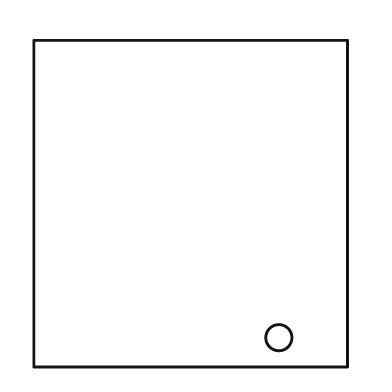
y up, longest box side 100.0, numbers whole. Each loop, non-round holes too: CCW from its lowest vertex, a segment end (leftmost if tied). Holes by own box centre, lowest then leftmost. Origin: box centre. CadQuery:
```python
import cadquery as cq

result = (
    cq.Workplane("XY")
    .moveTo(-48.0, -50.0)
    .lineTo(48.0, -50.0)
    .lineTo(48.0, 50.0)
    .lineTo(-48.0, 50.0)
    .close()
    .moveTo(27.0, -41.0)
    .circle(4.0)
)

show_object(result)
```